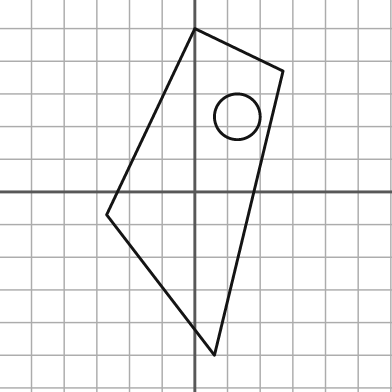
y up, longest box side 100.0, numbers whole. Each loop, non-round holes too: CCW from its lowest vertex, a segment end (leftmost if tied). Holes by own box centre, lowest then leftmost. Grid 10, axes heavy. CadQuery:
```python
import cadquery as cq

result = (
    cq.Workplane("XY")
    .moveTo(6.0, -50.0)
    .lineTo(27.0, 37.0)
    .lineTo(0.0, 50.0)
    .lineTo(-27.0, -7.0)
    .close()
    .moveTo(13.0, 23.0)
    .circle(7.0)
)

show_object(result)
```